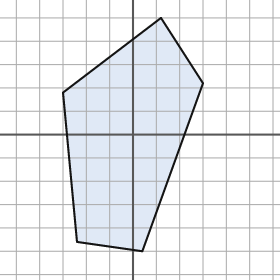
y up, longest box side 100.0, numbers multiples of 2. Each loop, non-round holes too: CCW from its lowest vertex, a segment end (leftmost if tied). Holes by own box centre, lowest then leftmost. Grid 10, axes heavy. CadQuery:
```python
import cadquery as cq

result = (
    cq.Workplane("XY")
    .moveTo(4.0, -50.0)
    .lineTo(30.0, 22.0)
    .lineTo(12.0, 50.0)
    .lineTo(-30.0, 18.0)
    .lineTo(-24.0, -46.0)
    .close()
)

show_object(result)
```